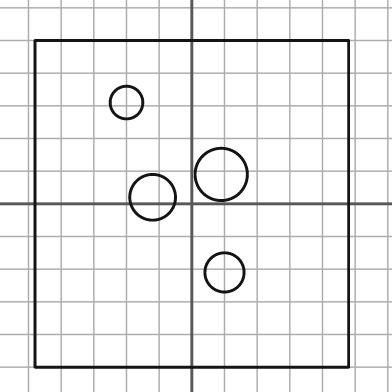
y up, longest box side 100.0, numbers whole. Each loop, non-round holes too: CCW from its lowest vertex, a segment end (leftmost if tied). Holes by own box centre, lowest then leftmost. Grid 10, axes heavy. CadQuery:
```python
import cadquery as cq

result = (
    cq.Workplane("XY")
    .moveTo(-48.0, -50.0)
    .lineTo(48.0, -50.0)
    .lineTo(48.0, 50.0)
    .lineTo(-48.0, 50.0)
    .close()
    .moveTo(10.0, -21.0)
    .circle(6.0)
    .moveTo(-12.0, 2.0)
    .circle(7.0)
    .moveTo(9.0, 9.0)
    .circle(8.0)
    .moveTo(-20.0, 31.0)
    .circle(5.0)
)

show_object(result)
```